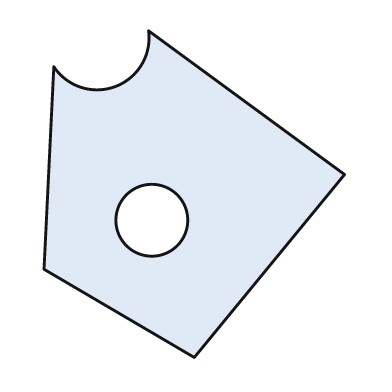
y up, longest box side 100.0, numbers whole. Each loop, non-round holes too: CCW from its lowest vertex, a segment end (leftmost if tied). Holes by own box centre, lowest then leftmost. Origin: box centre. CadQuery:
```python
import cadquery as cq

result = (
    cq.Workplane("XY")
    .moveTo(0.0, -50.0)
    .lineTo(46.0, 6.0)
    .lineTo(-14.0, 50.0)
    .threePointArc((-24.0, 33.0), (-43.0, 39.0))
    .lineTo(-46.0, -23.0)
    .close()
    .moveTo(-13.0, -8.0)
    .circle(11.0)
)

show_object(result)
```